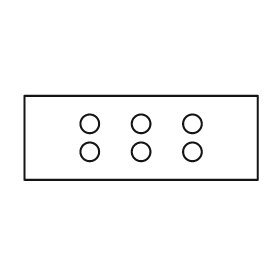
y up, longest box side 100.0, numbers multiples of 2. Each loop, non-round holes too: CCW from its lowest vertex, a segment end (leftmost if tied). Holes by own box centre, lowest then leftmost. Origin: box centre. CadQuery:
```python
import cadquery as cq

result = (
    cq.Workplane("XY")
    .moveTo(-50.0, -18.0)
    .lineTo(50.0, -18.0)
    .lineTo(50.0, 18.0)
    .lineTo(-50.0, 18.0)
    .close()
    .moveTo(-22.0, -6.0)
    .circle(4.0)
    .moveTo(0.0, -6.0)
    .circle(4.0)
    .moveTo(22.0, -6.0)
    .circle(4.0)
    .moveTo(-22.0, 6.0)
    .circle(4.0)
    .moveTo(0.0, 6.0)
    .circle(4.0)
    .moveTo(22.0, 6.0)
    .circle(4.0)
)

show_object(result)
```